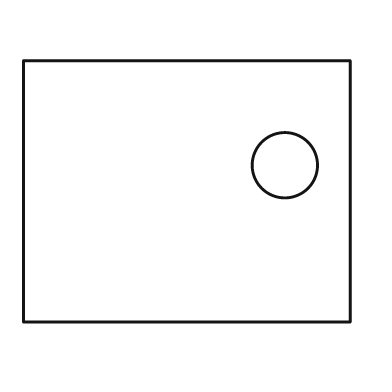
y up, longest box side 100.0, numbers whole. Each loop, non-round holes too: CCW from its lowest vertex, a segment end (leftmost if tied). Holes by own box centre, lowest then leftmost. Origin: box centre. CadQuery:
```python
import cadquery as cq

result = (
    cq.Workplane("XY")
    .moveTo(-50.0, -40.0)
    .lineTo(50.0, -40.0)
    .lineTo(50.0, 40.0)
    .lineTo(-50.0, 40.0)
    .close()
    .moveTo(30.0, 8.0)
    .circle(10.0)
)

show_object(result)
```